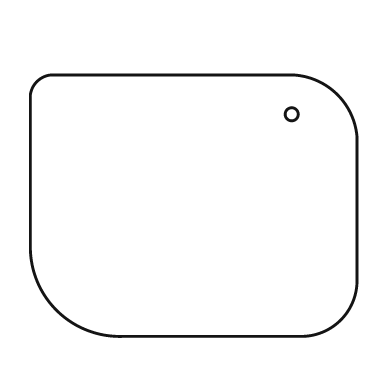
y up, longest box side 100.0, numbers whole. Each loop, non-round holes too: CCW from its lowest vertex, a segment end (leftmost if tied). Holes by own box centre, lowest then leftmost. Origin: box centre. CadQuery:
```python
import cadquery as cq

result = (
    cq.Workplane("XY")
    .moveTo(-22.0, -40.0)
    .lineTo(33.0, -40.0)
    .threePointArc((45.0, -35.0), (50.0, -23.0))
    .lineTo(50.0, 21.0)
    .threePointArc((44.0, 34.0), (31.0, 40.0))
    .lineTo(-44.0, 40.0)
    .threePointArc((-48.0, 38.0), (-50.0, 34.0))
    .lineTo(-50.0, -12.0)
    .threePointArc((-42.0, -32.0), (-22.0, -40.0))
    .close()
    .moveTo(30.0, 28.0)
    .circle(2.0)
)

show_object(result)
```